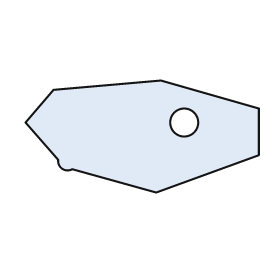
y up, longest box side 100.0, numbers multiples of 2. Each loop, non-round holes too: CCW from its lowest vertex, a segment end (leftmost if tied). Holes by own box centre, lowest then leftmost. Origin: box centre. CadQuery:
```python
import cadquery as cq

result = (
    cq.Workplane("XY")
    .moveTo(6.0, -24.0)
    .lineTo(50.0, -8.0)
    .lineTo(50.0, 12.0)
    .lineTo(8.0, 24.0)
    .lineTo(-38.0, 20.0)
    .lineTo(-50.0, 6.0)
    .lineTo(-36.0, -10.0)
    .threePointArc((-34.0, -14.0), (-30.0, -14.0))
    .close()
    .moveTo(18.0, 6.0)
    .circle(6.0)
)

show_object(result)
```